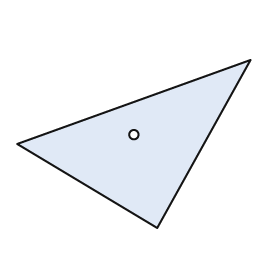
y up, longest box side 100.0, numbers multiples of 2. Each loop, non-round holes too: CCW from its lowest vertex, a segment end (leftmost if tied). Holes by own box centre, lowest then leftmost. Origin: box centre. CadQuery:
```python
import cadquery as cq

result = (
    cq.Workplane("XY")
    .moveTo(10.0, -36.0)
    .lineTo(50.0, 36.0)
    .lineTo(-50.0, 0.0)
    .close()
    .moveTo(0.0, 4.0)
    .circle(2.0)
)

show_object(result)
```